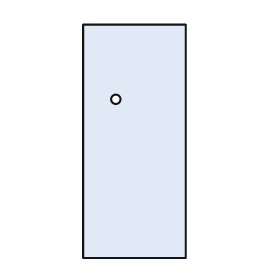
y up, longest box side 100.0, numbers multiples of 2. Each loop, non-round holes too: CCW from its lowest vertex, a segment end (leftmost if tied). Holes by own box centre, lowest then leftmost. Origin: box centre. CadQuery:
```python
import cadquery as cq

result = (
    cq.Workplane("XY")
    .moveTo(-22.0, -50.0)
    .lineTo(22.0, -50.0)
    .lineTo(22.0, 50.0)
    .lineTo(-22.0, 50.0)
    .close()
    .moveTo(-8.0, 18.0)
    .circle(2.0)
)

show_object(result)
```